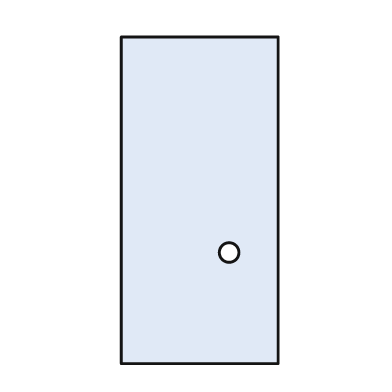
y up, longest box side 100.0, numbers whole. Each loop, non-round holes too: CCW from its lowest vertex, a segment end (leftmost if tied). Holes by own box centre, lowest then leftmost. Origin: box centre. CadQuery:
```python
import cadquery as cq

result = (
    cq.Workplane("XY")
    .moveTo(-24.0, -50.0)
    .lineTo(24.0, -50.0)
    .lineTo(24.0, 50.0)
    .lineTo(-24.0, 50.0)
    .close()
    .moveTo(9.0, -16.0)
    .circle(3.0)
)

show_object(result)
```